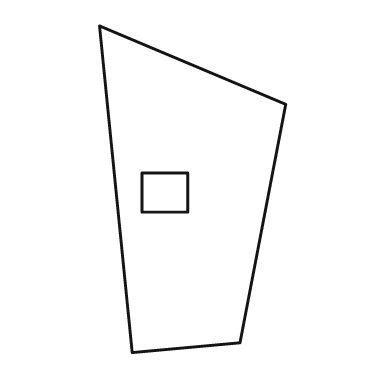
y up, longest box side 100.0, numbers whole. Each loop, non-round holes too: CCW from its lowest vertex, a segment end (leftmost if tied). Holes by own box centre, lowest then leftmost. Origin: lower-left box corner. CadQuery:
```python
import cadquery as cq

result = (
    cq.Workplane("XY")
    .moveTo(10.0, 0.0)
    .lineTo(43.0, 3.0)
    .lineTo(57.0, 76.0)
    .lineTo(0.0, 100.0)
    .close()
    .moveTo(13.0, 43.0)
    .lineTo(27.0, 43.0)
    .lineTo(27.0, 55.0)
    .lineTo(13.0, 55.0)
    .close()
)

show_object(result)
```